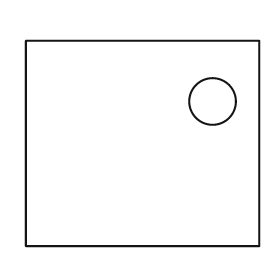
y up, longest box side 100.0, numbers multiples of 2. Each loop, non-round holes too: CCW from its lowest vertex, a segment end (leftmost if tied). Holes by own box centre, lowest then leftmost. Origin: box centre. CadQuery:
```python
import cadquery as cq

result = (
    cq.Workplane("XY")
    .moveTo(-50.0, -44.0)
    .lineTo(50.0, -44.0)
    .lineTo(50.0, 44.0)
    .lineTo(-50.0, 44.0)
    .close()
    .moveTo(30.0, 18.0)
    .circle(10.0)
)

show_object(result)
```